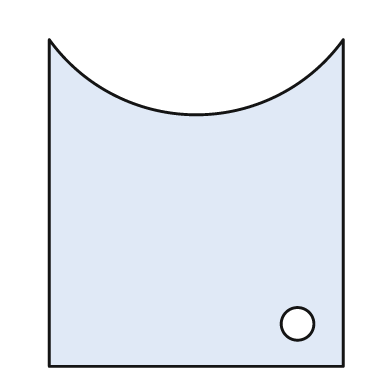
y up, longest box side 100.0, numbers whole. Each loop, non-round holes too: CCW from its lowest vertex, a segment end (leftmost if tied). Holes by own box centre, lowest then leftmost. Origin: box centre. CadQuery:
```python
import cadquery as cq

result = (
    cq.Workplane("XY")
    .moveTo(-45.0, -50.0)
    .lineTo(45.0, -50.0)
    .lineTo(45.0, 50.0)
    .threePointArc((0.0, 27.0), (-45.0, 50.0))
    .close()
    .moveTo(31.0, -37.0)
    .circle(5.0)
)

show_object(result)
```